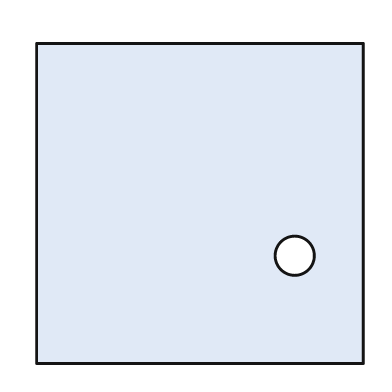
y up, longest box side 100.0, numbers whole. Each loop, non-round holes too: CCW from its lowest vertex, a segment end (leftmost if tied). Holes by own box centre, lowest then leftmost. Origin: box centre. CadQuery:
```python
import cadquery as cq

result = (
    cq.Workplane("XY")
    .moveTo(-50.0, -49.0)
    .lineTo(50.0, -49.0)
    .lineTo(50.0, 49.0)
    .lineTo(-50.0, 49.0)
    .close()
    .moveTo(29.0, -16.0)
    .circle(6.0)
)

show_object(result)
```